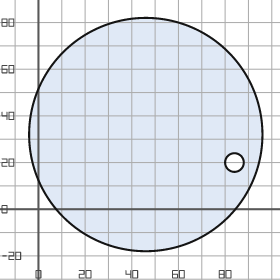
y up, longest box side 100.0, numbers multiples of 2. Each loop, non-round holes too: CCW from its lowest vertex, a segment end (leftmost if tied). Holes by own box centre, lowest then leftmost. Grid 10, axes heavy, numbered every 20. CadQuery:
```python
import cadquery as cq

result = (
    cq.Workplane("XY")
    .moveTo(46.0, 32.0)
    .circle(50.0)
    .moveTo(84.0, 20.0)
    .circle(4.0)
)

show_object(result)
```